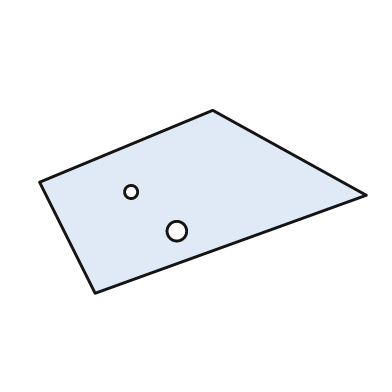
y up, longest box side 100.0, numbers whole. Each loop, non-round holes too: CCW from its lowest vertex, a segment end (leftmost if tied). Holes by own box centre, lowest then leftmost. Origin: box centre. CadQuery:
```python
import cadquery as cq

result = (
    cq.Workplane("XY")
    .moveTo(-33.0, -28.0)
    .lineTo(50.0, 2.0)
    .lineTo(3.0, 28.0)
    .lineTo(-50.0, 6.0)
    .close()
    .moveTo(-8.0, -9.0)
    .circle(3.0)
    .moveTo(-22.0, 3.0)
    .circle(2.0)
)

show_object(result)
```